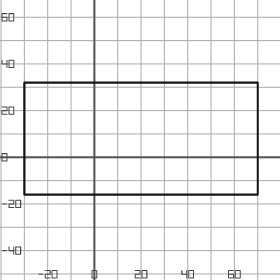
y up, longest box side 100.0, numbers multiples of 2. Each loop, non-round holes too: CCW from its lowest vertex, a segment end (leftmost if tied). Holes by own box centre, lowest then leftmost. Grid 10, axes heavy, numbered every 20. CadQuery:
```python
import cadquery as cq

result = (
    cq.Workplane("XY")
    .moveTo(-30.0, -16.0)
    .lineTo(70.0, -16.0)
    .lineTo(70.0, 32.0)
    .lineTo(-30.0, 32.0)
    .close()
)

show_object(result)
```